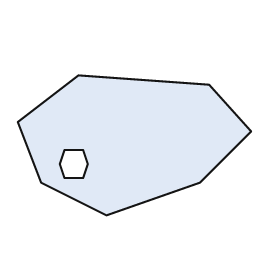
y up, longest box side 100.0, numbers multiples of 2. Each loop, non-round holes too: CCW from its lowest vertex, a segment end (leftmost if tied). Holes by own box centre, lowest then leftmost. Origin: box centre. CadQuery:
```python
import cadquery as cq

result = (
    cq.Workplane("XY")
    .moveTo(-12.0, -30.0)
    .lineTo(28.0, -16.0)
    .lineTo(50.0, 6.0)
    .lineTo(32.0, 26.0)
    .lineTo(-24.0, 30.0)
    .lineTo(-50.0, 10.0)
    .lineTo(-40.0, -16.0)
    .close()
    .moveTo(-30.0, -14.0)
    .lineTo(-22.0, -14.0)
    .lineTo(-20.0, -8.0)
    .lineTo(-22.0, -2.0)
    .lineTo(-30.0, -2.0)
    .lineTo(-32.0, -8.0)
    .close()
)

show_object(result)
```